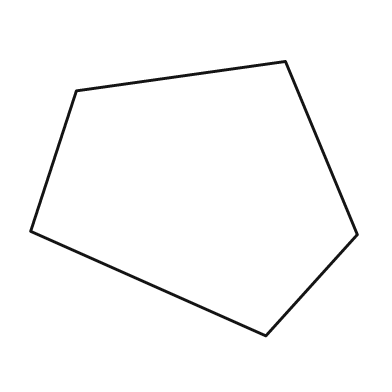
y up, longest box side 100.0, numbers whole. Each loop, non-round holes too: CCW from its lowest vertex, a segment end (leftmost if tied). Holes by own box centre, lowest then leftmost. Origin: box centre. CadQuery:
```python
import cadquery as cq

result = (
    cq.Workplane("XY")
    .moveTo(22.0, -42.0)
    .lineTo(50.0, -11.0)
    .lineTo(28.0, 42.0)
    .lineTo(-36.0, 33.0)
    .lineTo(-50.0, -10.0)
    .close()
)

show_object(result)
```